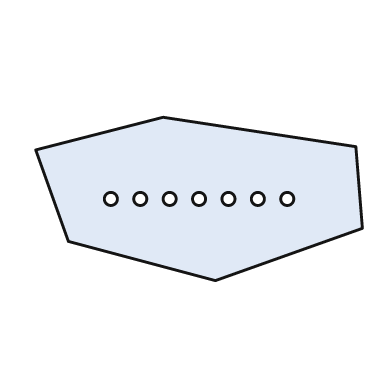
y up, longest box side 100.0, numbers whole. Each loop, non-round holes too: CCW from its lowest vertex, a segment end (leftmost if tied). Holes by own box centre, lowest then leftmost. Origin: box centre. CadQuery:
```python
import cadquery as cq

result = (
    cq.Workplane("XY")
    .moveTo(5.0, -25.0)
    .lineTo(50.0, -9.0)
    .lineTo(48.0, 16.0)
    .lineTo(-11.0, 25.0)
    .lineTo(-50.0, 15.0)
    .lineTo(-40.0, -13.0)
    .close()
    .moveTo(-27.0, 0.0)
    .circle(2.0)
    .moveTo(-18.0, 0.0)
    .circle(2.0)
    .moveTo(-9.0, 0.0)
    .circle(2.0)
    .moveTo(0.0, 0.0)
    .circle(2.0)
    .moveTo(9.0, 0.0)
    .circle(2.0)
    .moveTo(18.0, 0.0)
    .circle(2.0)
    .moveTo(27.0, 0.0)
    .circle(2.0)
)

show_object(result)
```